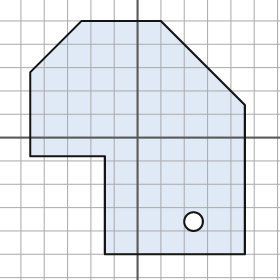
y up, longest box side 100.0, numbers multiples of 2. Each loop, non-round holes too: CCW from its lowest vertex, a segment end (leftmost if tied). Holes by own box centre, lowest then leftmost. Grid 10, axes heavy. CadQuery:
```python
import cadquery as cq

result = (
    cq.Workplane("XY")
    .moveTo(-14.0, -50.0)
    .lineTo(46.0, -50.0)
    .lineTo(46.0, 14.0)
    .lineTo(10.0, 50.0)
    .lineTo(-24.0, 50.0)
    .lineTo(-46.0, 28.0)
    .lineTo(-46.0, -8.0)
    .lineTo(-14.0, -8.0)
    .close()
    .moveTo(24.0, -36.0)
    .circle(4.0)
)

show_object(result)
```